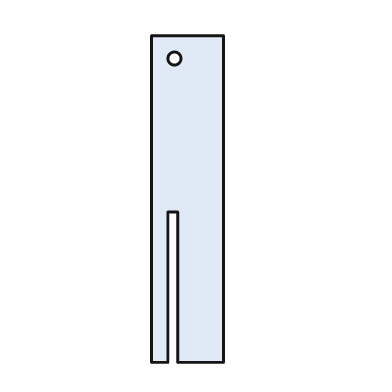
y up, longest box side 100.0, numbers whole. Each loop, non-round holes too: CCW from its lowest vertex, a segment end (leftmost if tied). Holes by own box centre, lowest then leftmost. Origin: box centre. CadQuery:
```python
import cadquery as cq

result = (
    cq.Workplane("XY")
    .moveTo(-11.0, -50.0)
    .lineTo(-6.0, -50.0)
    .lineTo(-6.0, -4.0)
    .lineTo(-3.0, -4.0)
    .lineTo(-3.0, -50.0)
    .lineTo(11.0, -50.0)
    .lineTo(11.0, 50.0)
    .lineTo(-11.0, 50.0)
    .close()
    .moveTo(-4.0, 43.0)
    .circle(2.0)
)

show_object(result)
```